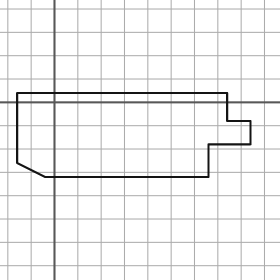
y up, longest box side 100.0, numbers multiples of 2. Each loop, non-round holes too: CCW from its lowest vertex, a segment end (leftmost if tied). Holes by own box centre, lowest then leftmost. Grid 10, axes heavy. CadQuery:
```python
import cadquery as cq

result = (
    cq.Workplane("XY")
    .moveTo(-4.0, -32.0)
    .lineTo(66.0, -32.0)
    .lineTo(66.0, -18.0)
    .lineTo(84.0, -18.0)
    .lineTo(84.0, -8.0)
    .lineTo(74.0, -8.0)
    .lineTo(74.0, 4.0)
    .lineTo(-16.0, 4.0)
    .lineTo(-16.0, -26.0)
    .close()
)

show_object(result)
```